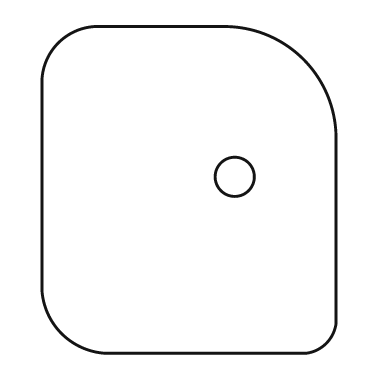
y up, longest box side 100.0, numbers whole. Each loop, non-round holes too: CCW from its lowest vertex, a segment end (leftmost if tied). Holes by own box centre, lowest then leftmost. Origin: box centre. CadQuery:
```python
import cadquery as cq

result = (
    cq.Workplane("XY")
    .moveTo(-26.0, -50.0)
    .lineTo(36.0, -50.0)
    .threePointArc((42.0, -47.0), (45.0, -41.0))
    .lineTo(45.0, 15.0)
    .threePointArc((35.0, 40.0), (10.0, 50.0))
    .lineTo(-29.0, 50.0)
    .threePointArc((-40.0, 45.0), (-45.0, 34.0))
    .lineTo(-45.0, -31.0)
    .threePointArc((-39.0, -44.0), (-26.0, -50.0))
    .close()
    .moveTo(14.0, 4.0)
    .circle(6.0)
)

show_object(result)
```